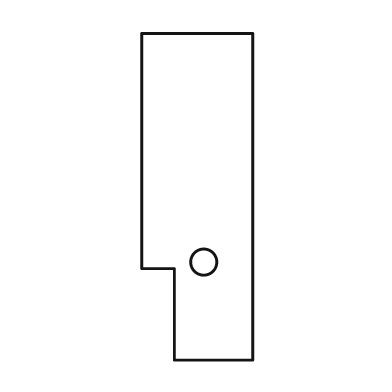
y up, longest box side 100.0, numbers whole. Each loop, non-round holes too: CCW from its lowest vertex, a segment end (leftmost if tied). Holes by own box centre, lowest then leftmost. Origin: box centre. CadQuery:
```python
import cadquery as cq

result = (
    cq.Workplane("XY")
    .moveTo(-7.0, -50.0)
    .lineTo(17.0, -50.0)
    .lineTo(17.0, 50.0)
    .lineTo(-17.0, 50.0)
    .lineTo(-17.0, -22.0)
    .lineTo(-7.0, -22.0)
    .close()
    .moveTo(2.0, -20.0)
    .circle(4.0)
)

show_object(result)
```